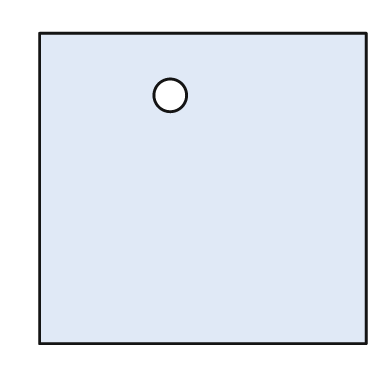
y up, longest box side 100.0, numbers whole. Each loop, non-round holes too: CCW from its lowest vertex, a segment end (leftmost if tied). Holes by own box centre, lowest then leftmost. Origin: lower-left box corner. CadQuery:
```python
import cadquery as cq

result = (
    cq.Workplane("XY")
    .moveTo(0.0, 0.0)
    .lineTo(100.0, 0.0)
    .lineTo(100.0, 95.0)
    .lineTo(0.0, 95.0)
    .close()
    .moveTo(40.0, 76.0)
    .circle(5.0)
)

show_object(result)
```